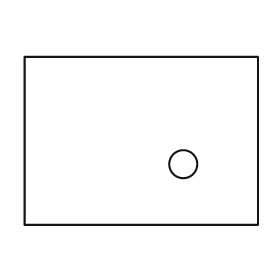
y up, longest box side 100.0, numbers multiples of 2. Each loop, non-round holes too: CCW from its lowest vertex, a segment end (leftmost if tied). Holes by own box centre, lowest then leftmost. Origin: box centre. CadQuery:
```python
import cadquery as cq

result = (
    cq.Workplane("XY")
    .moveTo(-50.0, -36.0)
    .lineTo(50.0, -36.0)
    .lineTo(50.0, 36.0)
    .lineTo(-50.0, 36.0)
    .close()
    .moveTo(18.0, -10.0)
    .circle(6.0)
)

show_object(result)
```